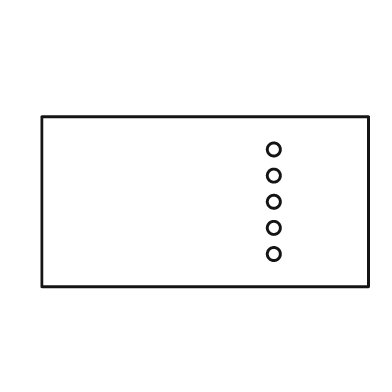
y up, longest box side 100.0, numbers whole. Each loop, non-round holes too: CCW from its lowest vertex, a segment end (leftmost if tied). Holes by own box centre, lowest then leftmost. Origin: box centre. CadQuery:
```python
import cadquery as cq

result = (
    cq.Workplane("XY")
    .moveTo(-50.0, -26.0)
    .lineTo(50.0, -26.0)
    .lineTo(50.0, 26.0)
    .lineTo(-50.0, 26.0)
    .close()
    .moveTo(21.0, -16.0)
    .circle(2.0)
    .moveTo(21.0, -8.0)
    .circle(2.0)
    .moveTo(21.0, 0.0)
    .circle(2.0)
    .moveTo(21.0, 8.0)
    .circle(2.0)
    .moveTo(21.0, 16.0)
    .circle(2.0)
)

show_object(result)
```